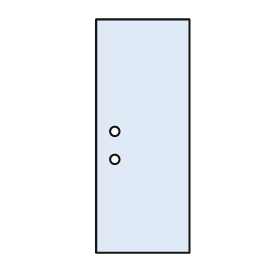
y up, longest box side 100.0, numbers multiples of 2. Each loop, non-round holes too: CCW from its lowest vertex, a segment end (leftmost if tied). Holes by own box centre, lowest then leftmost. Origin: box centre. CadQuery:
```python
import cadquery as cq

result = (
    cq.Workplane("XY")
    .moveTo(-20.0, -50.0)
    .lineTo(20.0, -50.0)
    .lineTo(20.0, 50.0)
    .lineTo(-20.0, 50.0)
    .close()
    .moveTo(-12.0, -10.0)
    .circle(2.0)
    .moveTo(-12.0, 2.0)
    .circle(2.0)
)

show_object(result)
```